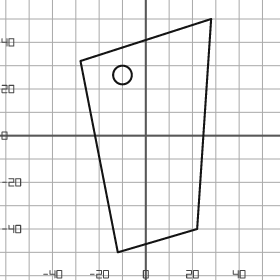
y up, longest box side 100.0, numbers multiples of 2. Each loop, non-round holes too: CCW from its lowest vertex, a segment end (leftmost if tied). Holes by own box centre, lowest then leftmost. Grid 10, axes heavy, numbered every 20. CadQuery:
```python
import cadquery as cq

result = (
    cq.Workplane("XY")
    .moveTo(-12.0, -50.0)
    .lineTo(22.0, -40.0)
    .lineTo(28.0, 50.0)
    .lineTo(-28.0, 32.0)
    .close()
    .moveTo(-10.0, 26.0)
    .circle(4.0)
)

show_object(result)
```